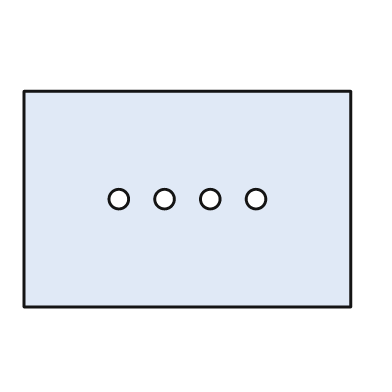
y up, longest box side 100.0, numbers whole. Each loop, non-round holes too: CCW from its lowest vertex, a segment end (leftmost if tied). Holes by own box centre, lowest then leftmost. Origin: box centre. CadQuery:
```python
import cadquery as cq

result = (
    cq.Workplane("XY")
    .moveTo(-50.0, -33.0)
    .lineTo(50.0, -33.0)
    .lineTo(50.0, 33.0)
    .lineTo(-50.0, 33.0)
    .close()
    .moveTo(-21.0, 0.0)
    .circle(3.0)
    .moveTo(-7.0, 0.0)
    .circle(3.0)
    .moveTo(7.0, 0.0)
    .circle(3.0)
    .moveTo(21.0, 0.0)
    .circle(3.0)
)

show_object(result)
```